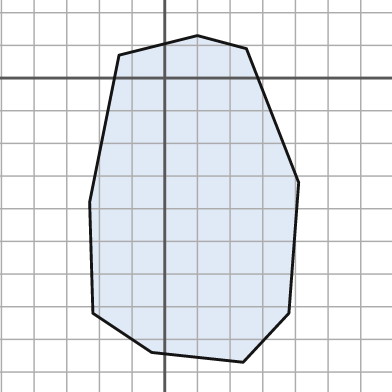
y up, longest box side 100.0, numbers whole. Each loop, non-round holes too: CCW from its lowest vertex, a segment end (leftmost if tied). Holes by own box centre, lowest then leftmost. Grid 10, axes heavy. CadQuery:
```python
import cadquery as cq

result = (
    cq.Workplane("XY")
    .moveTo(24.0, -87.0)
    .lineTo(38.0, -72.0)
    .lineTo(41.0, -32.0)
    .lineTo(25.0, 9.0)
    .lineTo(10.0, 13.0)
    .lineTo(-14.0, 7.0)
    .lineTo(-23.0, -38.0)
    .lineTo(-22.0, -72.0)
    .lineTo(-4.0, -84.0)
    .close()
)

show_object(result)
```